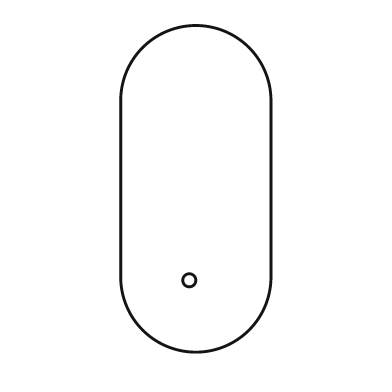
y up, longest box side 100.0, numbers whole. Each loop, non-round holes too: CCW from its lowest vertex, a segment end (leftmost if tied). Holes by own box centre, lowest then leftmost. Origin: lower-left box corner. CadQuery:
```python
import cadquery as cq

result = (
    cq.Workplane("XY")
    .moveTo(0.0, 23.0)
    .threePointArc((23.0, 0.0), (46.0, 23.0))
    .lineTo(46.0, 77.0)
    .threePointArc((23.0, 100.0), (0.0, 77.0))
    .close()
    .moveTo(21.0, 22.0)
    .circle(2.0)
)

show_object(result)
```